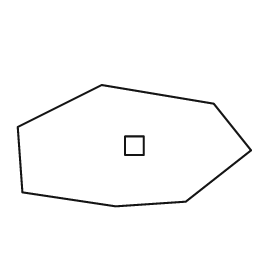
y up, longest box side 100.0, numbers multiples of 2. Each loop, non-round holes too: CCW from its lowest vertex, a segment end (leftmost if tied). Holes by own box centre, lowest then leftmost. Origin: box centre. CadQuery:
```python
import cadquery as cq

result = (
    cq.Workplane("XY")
    .moveTo(-8.0, -26.0)
    .lineTo(22.0, -24.0)
    .lineTo(50.0, -2.0)
    .lineTo(34.0, 18.0)
    .lineTo(-14.0, 26.0)
    .lineTo(-50.0, 8.0)
    .lineTo(-48.0, -20.0)
    .close()
    .moveTo(-4.0, -4.0)
    .lineTo(4.0, -4.0)
    .lineTo(4.0, 4.0)
    .lineTo(-4.0, 4.0)
    .close()
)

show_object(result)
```